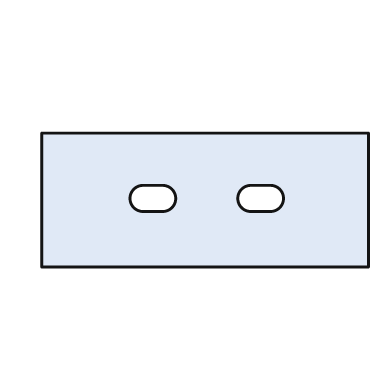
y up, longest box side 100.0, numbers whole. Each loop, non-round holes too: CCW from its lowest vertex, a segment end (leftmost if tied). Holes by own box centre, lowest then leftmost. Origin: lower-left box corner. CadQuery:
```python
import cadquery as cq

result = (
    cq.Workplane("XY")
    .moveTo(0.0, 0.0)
    .lineTo(100.0, 0.0)
    .lineTo(100.0, 41.0)
    .lineTo(0.0, 41.0)
    .close()
    .moveTo(31.0, 17.0)
    .lineTo(37.0, 17.0)
    .threePointArc((41.0, 21.0), (37.0, 25.0))
    .lineTo(31.0, 25.0)
    .threePointArc((27.0, 21.0), (31.0, 17.0))
    .close()
    .moveTo(64.0, 17.0)
    .lineTo(70.0, 17.0)
    .threePointArc((74.0, 21.0), (70.0, 25.0))
    .lineTo(64.0, 25.0)
    .threePointArc((60.0, 21.0), (64.0, 17.0))
    .close()
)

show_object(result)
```